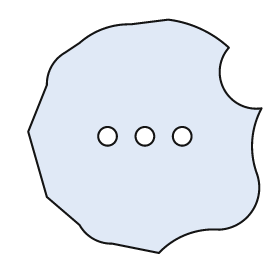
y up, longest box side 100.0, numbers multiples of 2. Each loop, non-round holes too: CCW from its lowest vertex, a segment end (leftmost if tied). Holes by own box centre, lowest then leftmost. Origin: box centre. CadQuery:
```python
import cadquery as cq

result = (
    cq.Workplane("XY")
    .moveTo(6.0, -50.0)
    .threePointArc((18.0, -42.0), (32.0, -40.0))
    .threePointArc((46.0, -32.0), (48.0, -16.0))
    .threePointArc((46.0, -2.0), (50.0, 12.0))
    .threePointArc((34.0, 20.0), (36.0, 38.0))
    .threePointArc((24.0, 46.0), (10.0, 50.0))
    .lineTo(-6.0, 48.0)
    .threePointArc((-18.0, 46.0), (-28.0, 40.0))
    .lineTo(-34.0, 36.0)
    .threePointArc((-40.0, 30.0), (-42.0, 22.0))
    .lineTo(-50.0, 2.0)
    .lineTo(-42.0, -26.0)
    .lineTo(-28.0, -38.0)
    .threePointArc((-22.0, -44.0), (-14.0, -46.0))
    .close()
    .moveTo(-16.0, 0.0)
    .circle(4.0)
    .moveTo(0.0, 0.0)
    .circle(4.0)
    .moveTo(16.0, 0.0)
    .circle(4.0)
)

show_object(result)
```